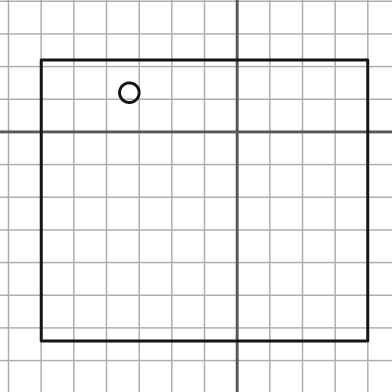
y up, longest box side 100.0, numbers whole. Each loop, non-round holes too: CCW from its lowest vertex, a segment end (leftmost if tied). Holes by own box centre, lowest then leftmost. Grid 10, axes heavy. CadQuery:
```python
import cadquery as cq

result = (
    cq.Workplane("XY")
    .moveTo(-60.0, -64.0)
    .lineTo(40.0, -64.0)
    .lineTo(40.0, 22.0)
    .lineTo(-60.0, 22.0)
    .close()
    .moveTo(-33.0, 12.0)
    .circle(3.0)
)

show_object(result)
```